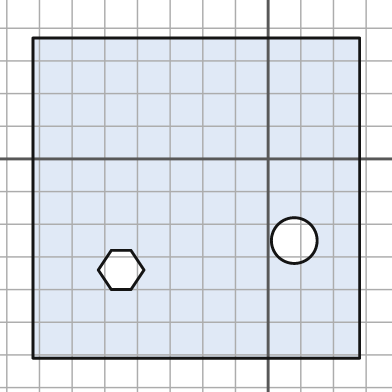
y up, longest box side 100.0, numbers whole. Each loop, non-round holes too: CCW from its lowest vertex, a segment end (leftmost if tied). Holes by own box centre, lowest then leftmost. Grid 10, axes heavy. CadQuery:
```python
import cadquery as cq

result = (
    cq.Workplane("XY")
    .moveTo(-72.0, -61.0)
    .lineTo(28.0, -61.0)
    .lineTo(28.0, 37.0)
    .lineTo(-72.0, 37.0)
    .close()
    .moveTo(-48.0, -40.0)
    .lineTo(-42.0, -40.0)
    .lineTo(-38.0, -34.0)
    .lineTo(-42.0, -28.0)
    .lineTo(-48.0, -28.0)
    .lineTo(-52.0, -34.0)
    .close()
    .moveTo(8.0, -25.0)
    .circle(7.0)
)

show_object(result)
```